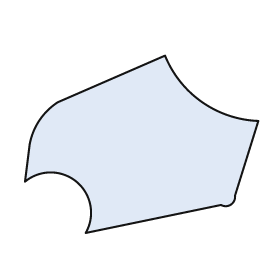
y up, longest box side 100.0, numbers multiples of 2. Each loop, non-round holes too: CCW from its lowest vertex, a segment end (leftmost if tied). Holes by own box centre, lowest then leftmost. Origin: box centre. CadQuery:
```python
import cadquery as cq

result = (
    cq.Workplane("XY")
    .moveTo(-24.0, -38.0)
    .lineTo(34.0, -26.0)
    .threePointArc((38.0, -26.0), (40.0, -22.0))
    .lineTo(50.0, 10.0)
    .threePointArc((26.0, 18.0), (10.0, 38.0))
    .lineTo(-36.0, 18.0)
    .threePointArc((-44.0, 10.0), (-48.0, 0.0))
    .lineTo(-50.0, -16.0)
    .threePointArc((-28.0, -16.0), (-24.0, -38.0))
    .close()
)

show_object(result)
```